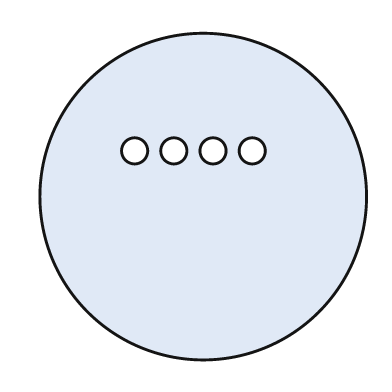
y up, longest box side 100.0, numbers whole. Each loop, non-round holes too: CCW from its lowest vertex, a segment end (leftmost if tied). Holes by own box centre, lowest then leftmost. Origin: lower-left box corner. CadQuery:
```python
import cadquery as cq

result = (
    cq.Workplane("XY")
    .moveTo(50.0, 50.0)
    .circle(50.0)
    .moveTo(29.0, 64.0)
    .circle(4.0)
    .moveTo(41.0, 64.0)
    .circle(4.0)
    .moveTo(53.0, 64.0)
    .circle(4.0)
    .moveTo(65.0, 64.0)
    .circle(4.0)
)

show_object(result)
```